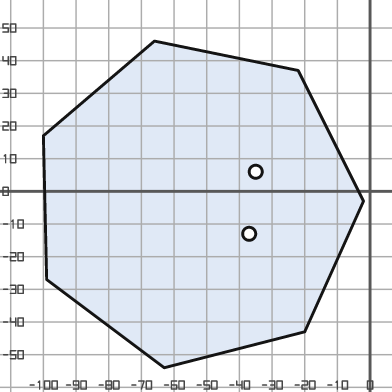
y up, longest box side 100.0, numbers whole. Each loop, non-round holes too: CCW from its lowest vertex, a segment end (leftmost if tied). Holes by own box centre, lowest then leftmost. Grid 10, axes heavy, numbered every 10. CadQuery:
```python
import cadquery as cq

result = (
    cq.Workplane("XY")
    .moveTo(-63.0, -54.0)
    .lineTo(-20.0, -43.0)
    .lineTo(-2.0, -3.0)
    .lineTo(-22.0, 37.0)
    .lineTo(-66.0, 46.0)
    .lineTo(-100.0, 17.0)
    .lineTo(-99.0, -27.0)
    .close()
    .moveTo(-37.0, -13.0)
    .circle(2.0)
    .moveTo(-35.0, 6.0)
    .circle(2.0)
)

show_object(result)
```